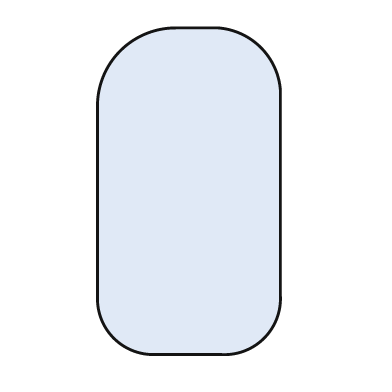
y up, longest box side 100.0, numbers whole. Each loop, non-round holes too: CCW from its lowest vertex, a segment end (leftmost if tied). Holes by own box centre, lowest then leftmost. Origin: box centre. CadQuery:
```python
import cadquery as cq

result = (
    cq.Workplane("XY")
    .moveTo(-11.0, -50.0)
    .lineTo(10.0, -50.0)
    .threePointArc((23.0, -45.0), (28.0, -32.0))
    .lineTo(28.0, 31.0)
    .threePointArc((22.0, 44.0), (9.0, 50.0))
    .lineTo(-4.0, 50.0)
    .threePointArc((-21.0, 43.0), (-28.0, 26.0))
    .lineTo(-28.0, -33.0)
    .threePointArc((-23.0, -45.0), (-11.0, -50.0))
    .close()
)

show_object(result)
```